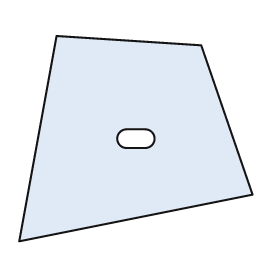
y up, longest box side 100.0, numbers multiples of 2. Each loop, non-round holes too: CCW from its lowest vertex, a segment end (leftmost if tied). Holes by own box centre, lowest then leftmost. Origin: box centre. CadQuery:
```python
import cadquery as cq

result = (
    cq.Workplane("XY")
    .moveTo(-50.0, -44.0)
    .lineTo(50.0, -24.0)
    .lineTo(28.0, 40.0)
    .lineTo(-34.0, 44.0)
    .close()
    .moveTo(-4.0, -4.0)
    .lineTo(4.0, -4.0)
    .threePointArc((8.0, 0.0), (4.0, 4.0))
    .lineTo(-4.0, 4.0)
    .threePointArc((-8.0, 0.0), (-4.0, -4.0))
    .close()
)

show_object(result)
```